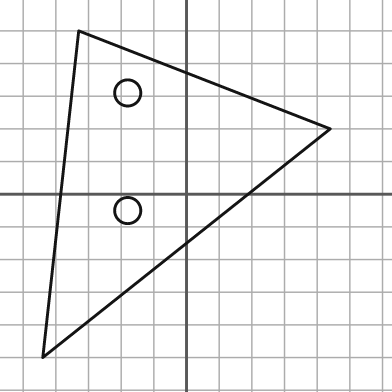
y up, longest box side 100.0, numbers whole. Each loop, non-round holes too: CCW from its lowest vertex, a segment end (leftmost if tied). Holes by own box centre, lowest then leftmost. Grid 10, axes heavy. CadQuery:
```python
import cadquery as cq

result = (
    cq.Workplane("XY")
    .moveTo(-44.0, -50.0)
    .lineTo(44.0, 20.0)
    .lineTo(-33.0, 50.0)
    .close()
    .moveTo(-18.0, -5.0)
    .circle(4.0)
    .moveTo(-18.0, 31.0)
    .circle(4.0)
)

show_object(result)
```